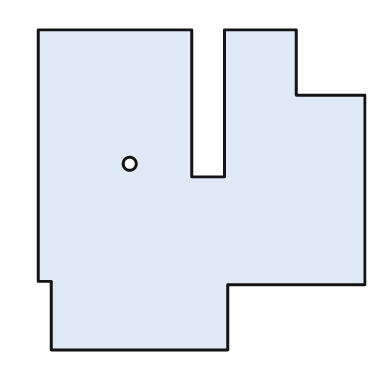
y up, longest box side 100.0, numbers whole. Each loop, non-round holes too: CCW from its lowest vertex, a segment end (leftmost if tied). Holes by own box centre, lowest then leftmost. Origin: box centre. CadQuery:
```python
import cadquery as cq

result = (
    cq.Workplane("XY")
    .moveTo(-46.0, -49.0)
    .lineTo(8.0, -49.0)
    .lineTo(8.0, -29.0)
    .lineTo(50.0, -29.0)
    .lineTo(50.0, 29.0)
    .lineTo(29.0, 29.0)
    .lineTo(29.0, 49.0)
    .lineTo(7.0, 49.0)
    .lineTo(7.0, 4.0)
    .lineTo(-3.0, 4.0)
    .lineTo(-3.0, 49.0)
    .lineTo(-50.0, 49.0)
    .lineTo(-50.0, -28.0)
    .lineTo(-46.0, -28.0)
    .close()
    .moveTo(-22.0, 8.0)
    .circle(2.0)
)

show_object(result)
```